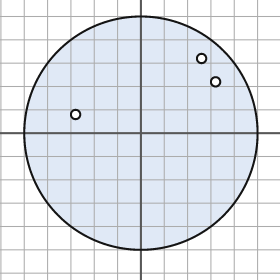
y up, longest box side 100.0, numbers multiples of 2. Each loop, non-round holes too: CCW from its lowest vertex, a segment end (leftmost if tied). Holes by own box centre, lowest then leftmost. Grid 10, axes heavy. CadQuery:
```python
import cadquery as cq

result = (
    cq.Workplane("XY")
    .moveTo(0.0, 0.0)
    .circle(50.0)
    .moveTo(-28.0, 8.0)
    .circle(2.0)
    .moveTo(32.0, 22.0)
    .circle(2.0)
    .moveTo(26.0, 32.0)
    .circle(2.0)
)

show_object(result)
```